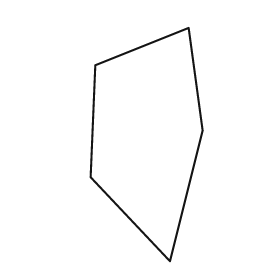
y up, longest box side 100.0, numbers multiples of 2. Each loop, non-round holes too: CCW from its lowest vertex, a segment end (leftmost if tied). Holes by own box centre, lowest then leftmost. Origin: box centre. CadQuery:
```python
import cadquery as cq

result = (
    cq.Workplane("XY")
    .moveTo(10.0, -50.0)
    .lineTo(24.0, 6.0)
    .lineTo(18.0, 50.0)
    .lineTo(-22.0, 34.0)
    .lineTo(-24.0, -14.0)
    .close()
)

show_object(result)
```